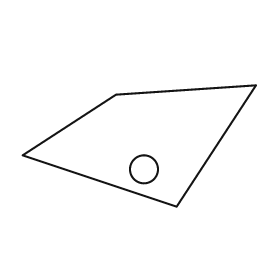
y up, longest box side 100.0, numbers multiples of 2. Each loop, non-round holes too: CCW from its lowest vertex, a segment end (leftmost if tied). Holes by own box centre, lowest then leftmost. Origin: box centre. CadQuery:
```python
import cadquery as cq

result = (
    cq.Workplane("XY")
    .moveTo(16.0, -26.0)
    .lineTo(50.0, 26.0)
    .lineTo(-10.0, 22.0)
    .lineTo(-50.0, -4.0)
    .close()
    .moveTo(2.0, -10.0)
    .circle(6.0)
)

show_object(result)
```